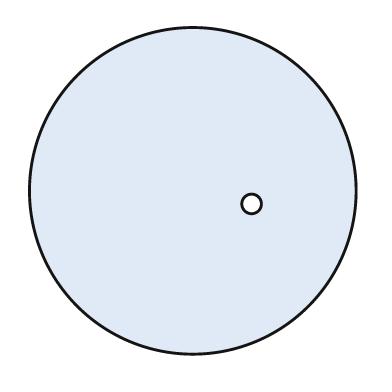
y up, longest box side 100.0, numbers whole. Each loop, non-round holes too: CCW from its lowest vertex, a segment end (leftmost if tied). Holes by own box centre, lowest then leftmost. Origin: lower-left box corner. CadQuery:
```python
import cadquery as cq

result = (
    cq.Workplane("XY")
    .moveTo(50.0, 50.0)
    .circle(50.0)
    .moveTo(68.0, 46.0)
    .circle(3.0)
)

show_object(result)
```